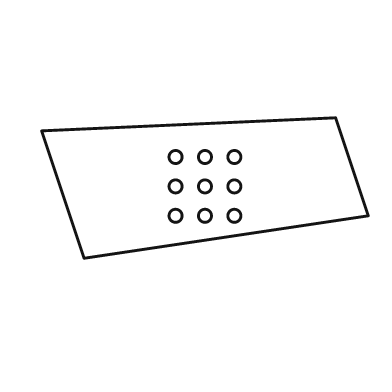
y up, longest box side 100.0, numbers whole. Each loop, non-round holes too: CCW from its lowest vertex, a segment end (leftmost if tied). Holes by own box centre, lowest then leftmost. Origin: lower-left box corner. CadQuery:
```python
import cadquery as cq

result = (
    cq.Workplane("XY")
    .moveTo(13.0, 0.0)
    .lineTo(100.0, 13.0)
    .lineTo(90.0, 43.0)
    .lineTo(0.0, 39.0)
    .close()
    .moveTo(41.0, 13.0)
    .circle(2.0)
    .moveTo(50.0, 13.0)
    .circle(2.0)
    .moveTo(59.0, 13.0)
    .circle(2.0)
    .moveTo(41.0, 22.0)
    .circle(2.0)
    .moveTo(50.0, 22.0)
    .circle(2.0)
    .moveTo(59.0, 22.0)
    .circle(2.0)
    .moveTo(41.0, 31.0)
    .circle(2.0)
    .moveTo(50.0, 31.0)
    .circle(2.0)
    .moveTo(59.0, 31.0)
    .circle(2.0)
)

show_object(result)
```